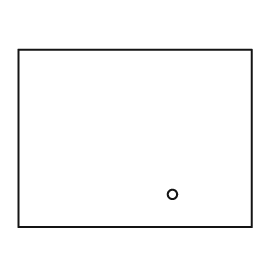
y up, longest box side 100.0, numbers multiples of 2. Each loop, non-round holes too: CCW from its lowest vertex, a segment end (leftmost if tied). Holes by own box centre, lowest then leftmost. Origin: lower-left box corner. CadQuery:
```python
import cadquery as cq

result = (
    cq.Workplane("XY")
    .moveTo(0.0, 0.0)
    .lineTo(100.0, 0.0)
    .lineTo(100.0, 76.0)
    .lineTo(0.0, 76.0)
    .close()
    .moveTo(66.0, 14.0)
    .circle(2.0)
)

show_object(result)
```